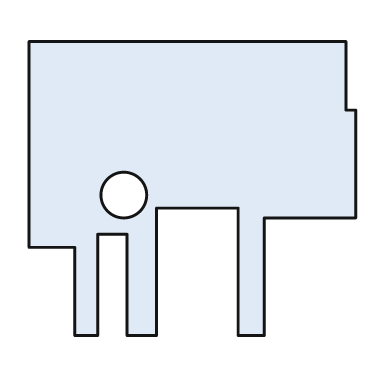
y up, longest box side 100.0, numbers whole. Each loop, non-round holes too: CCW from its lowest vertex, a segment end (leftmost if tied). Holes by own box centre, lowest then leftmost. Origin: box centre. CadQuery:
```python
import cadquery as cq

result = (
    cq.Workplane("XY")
    .moveTo(-36.0, -45.0)
    .lineTo(-29.0, -45.0)
    .lineTo(-29.0, -14.0)
    .lineTo(-20.0, -14.0)
    .lineTo(-20.0, -45.0)
    .lineTo(-11.0, -45.0)
    .lineTo(-11.0, -6.0)
    .lineTo(14.0, -6.0)
    .lineTo(14.0, -45.0)
    .lineTo(22.0, -45.0)
    .lineTo(22.0, -9.0)
    .lineTo(50.0, -9.0)
    .lineTo(50.0, 24.0)
    .lineTo(47.0, 24.0)
    .lineTo(47.0, 45.0)
    .lineTo(-50.0, 45.0)
    .lineTo(-50.0, -18.0)
    .lineTo(-36.0, -18.0)
    .close()
    .moveTo(-21.0, -2.0)
    .circle(7.0)
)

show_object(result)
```